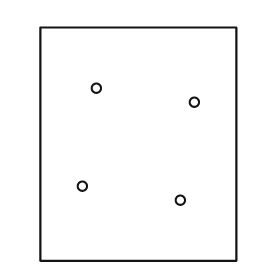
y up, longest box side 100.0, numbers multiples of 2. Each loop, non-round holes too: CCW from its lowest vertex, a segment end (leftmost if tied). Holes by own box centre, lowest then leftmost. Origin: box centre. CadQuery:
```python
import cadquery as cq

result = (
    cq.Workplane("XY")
    .moveTo(-42.0, -50.0)
    .lineTo(42.0, -50.0)
    .lineTo(42.0, 50.0)
    .lineTo(-42.0, 50.0)
    .close()
    .moveTo(18.0, -24.0)
    .circle(2.0)
    .moveTo(-24.0, -18.0)
    .circle(2.0)
    .moveTo(24.0, 18.0)
    .circle(2.0)
    .moveTo(-18.0, 24.0)
    .circle(2.0)
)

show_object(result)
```